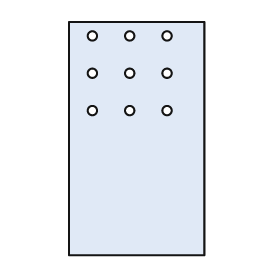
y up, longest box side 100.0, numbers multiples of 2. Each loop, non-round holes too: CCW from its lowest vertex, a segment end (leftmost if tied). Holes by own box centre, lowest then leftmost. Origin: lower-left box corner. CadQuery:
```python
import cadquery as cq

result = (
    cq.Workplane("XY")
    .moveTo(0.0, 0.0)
    .lineTo(58.0, 0.0)
    .lineTo(58.0, 100.0)
    .lineTo(0.0, 100.0)
    .close()
    .moveTo(10.0, 62.0)
    .circle(2.0)
    .moveTo(26.0, 62.0)
    .circle(2.0)
    .moveTo(42.0, 62.0)
    .circle(2.0)
    .moveTo(10.0, 78.0)
    .circle(2.0)
    .moveTo(26.0, 78.0)
    .circle(2.0)
    .moveTo(42.0, 78.0)
    .circle(2.0)
    .moveTo(10.0, 94.0)
    .circle(2.0)
    .moveTo(26.0, 94.0)
    .circle(2.0)
    .moveTo(42.0, 94.0)
    .circle(2.0)
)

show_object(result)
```